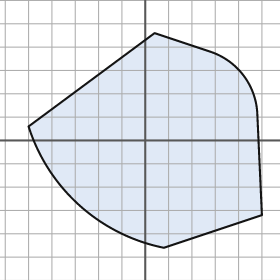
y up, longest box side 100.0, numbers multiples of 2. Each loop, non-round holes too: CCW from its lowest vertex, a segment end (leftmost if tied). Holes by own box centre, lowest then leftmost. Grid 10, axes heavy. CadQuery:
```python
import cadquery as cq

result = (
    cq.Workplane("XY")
    .moveTo(8.0, -46.0)
    .lineTo(50.0, -32.0)
    .lineTo(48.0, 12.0)
    .threePointArc((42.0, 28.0), (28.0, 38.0))
    .lineTo(4.0, 46.0)
    .lineTo(-50.0, 6.0)
    .threePointArc((-28.0, -28.0), (8.0, -46.0))
    .close()
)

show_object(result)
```